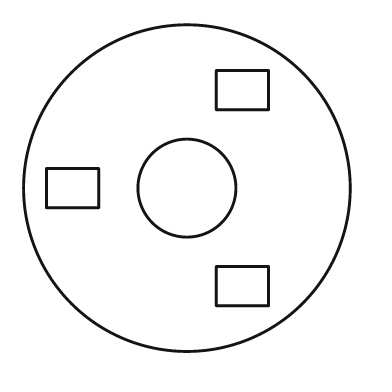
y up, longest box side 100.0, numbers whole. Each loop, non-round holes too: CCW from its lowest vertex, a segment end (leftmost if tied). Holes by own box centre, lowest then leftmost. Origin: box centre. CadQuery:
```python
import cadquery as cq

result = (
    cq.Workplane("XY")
    .moveTo(0.0, 0.0)
    .circle(50.0)
    .moveTo(9.0, -36.0)
    .lineTo(25.0, -36.0)
    .lineTo(25.0, -24.0)
    .lineTo(9.0, -24.0)
    .close()
    .moveTo(-43.0, -6.0)
    .lineTo(-27.0, -6.0)
    .lineTo(-27.0, 6.0)
    .lineTo(-43.0, 6.0)
    .close()
    .moveTo(0.0, 0.0)
    .circle(15.0)
    .moveTo(9.0, 24.0)
    .lineTo(25.0, 24.0)
    .lineTo(25.0, 36.0)
    .lineTo(9.0, 36.0)
    .close()
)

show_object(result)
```